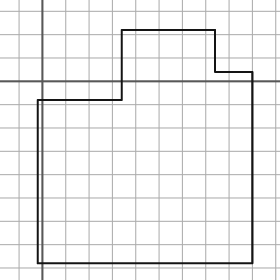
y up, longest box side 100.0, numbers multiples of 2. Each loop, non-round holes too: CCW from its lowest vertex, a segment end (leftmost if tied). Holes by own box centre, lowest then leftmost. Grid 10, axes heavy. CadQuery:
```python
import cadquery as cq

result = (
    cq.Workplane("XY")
    .moveTo(-2.0, -78.0)
    .lineTo(90.0, -78.0)
    .lineTo(90.0, 4.0)
    .lineTo(74.0, 4.0)
    .lineTo(74.0, 22.0)
    .lineTo(34.0, 22.0)
    .lineTo(34.0, -8.0)
    .lineTo(-2.0, -8.0)
    .close()
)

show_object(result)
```